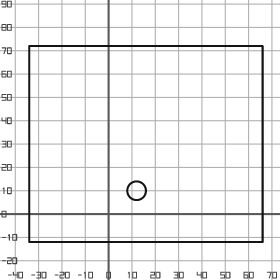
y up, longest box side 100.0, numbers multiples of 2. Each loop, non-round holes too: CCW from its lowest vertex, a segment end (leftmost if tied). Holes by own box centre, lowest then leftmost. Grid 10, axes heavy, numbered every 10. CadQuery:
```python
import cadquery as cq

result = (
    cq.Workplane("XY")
    .moveTo(-34.0, -12.0)
    .lineTo(66.0, -12.0)
    .lineTo(66.0, 72.0)
    .lineTo(-34.0, 72.0)
    .close()
    .moveTo(12.0, 10.0)
    .circle(4.0)
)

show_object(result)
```